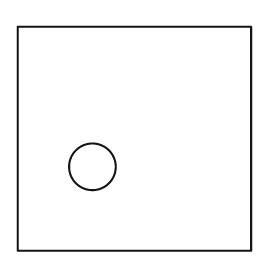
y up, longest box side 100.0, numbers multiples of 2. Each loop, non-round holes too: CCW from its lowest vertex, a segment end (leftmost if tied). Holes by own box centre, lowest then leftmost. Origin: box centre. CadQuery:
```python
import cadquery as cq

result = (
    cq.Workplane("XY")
    .moveTo(-50.0, -48.0)
    .lineTo(50.0, -48.0)
    .lineTo(50.0, 48.0)
    .lineTo(-50.0, 48.0)
    .close()
    .moveTo(-18.0, -12.0)
    .circle(10.0)
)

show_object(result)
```